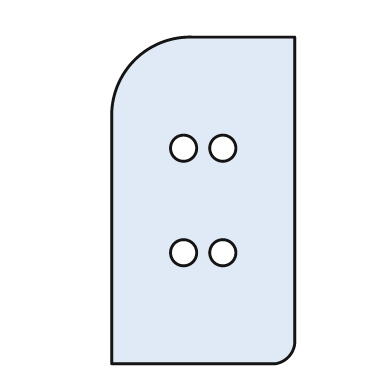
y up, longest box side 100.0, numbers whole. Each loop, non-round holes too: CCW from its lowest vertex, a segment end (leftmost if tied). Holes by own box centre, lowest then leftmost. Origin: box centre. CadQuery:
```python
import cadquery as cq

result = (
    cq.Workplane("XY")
    .moveTo(-28.0, -50.0)
    .lineTo(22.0, -50.0)
    .threePointArc((26.0, -48.0), (28.0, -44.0))
    .lineTo(28.0, 50.0)
    .lineTo(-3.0, 50.0)
    .threePointArc((-21.0, 43.0), (-28.0, 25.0))
    .close()
    .moveTo(-6.0, -16.0)
    .circle(4.0)
    .moveTo(6.0, -16.0)
    .circle(4.0)
    .moveTo(-6.0, 16.0)
    .circle(4.0)
    .moveTo(6.0, 16.0)
    .circle(4.0)
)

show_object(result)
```